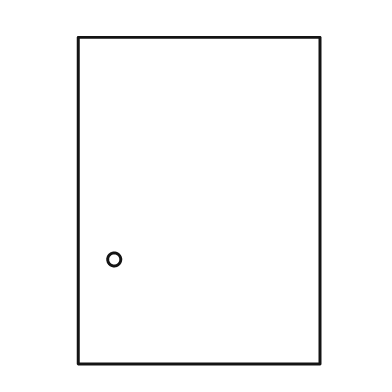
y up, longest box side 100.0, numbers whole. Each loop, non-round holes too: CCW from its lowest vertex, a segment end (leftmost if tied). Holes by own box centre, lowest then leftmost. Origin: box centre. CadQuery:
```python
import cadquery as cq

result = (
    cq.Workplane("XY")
    .moveTo(-37.0, -50.0)
    .lineTo(37.0, -50.0)
    .lineTo(37.0, 50.0)
    .lineTo(-37.0, 50.0)
    .close()
    .moveTo(-26.0, -18.0)
    .circle(2.0)
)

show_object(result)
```